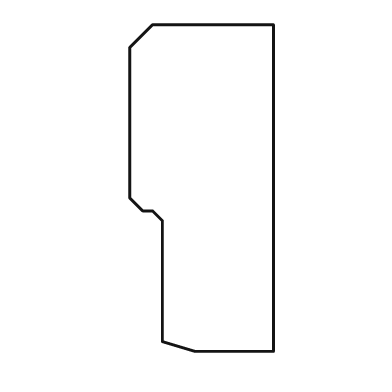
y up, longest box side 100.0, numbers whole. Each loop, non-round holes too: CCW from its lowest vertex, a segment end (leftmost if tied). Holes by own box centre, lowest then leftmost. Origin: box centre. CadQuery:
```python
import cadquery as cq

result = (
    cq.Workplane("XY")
    .moveTo(-2.0, -50.0)
    .lineTo(22.0, -50.0)
    .lineTo(22.0, 50.0)
    .lineTo(-15.0, 50.0)
    .lineTo(-22.0, 43.0)
    .lineTo(-22.0, -3.0)
    .lineTo(-18.0, -7.0)
    .lineTo(-15.0, -7.0)
    .lineTo(-12.0, -10.0)
    .lineTo(-12.0, -47.0)
    .close()
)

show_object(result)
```